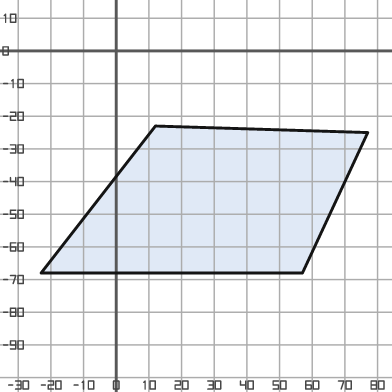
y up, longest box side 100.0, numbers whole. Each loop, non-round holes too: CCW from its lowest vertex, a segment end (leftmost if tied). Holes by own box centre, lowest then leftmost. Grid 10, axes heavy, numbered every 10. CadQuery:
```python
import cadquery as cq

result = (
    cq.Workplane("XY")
    .moveTo(-23.0, -68.0)
    .lineTo(57.0, -68.0)
    .lineTo(77.0, -25.0)
    .lineTo(12.0, -23.0)
    .close()
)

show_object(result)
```